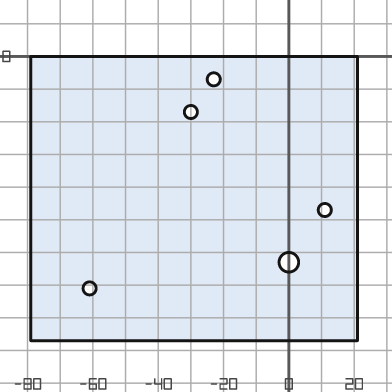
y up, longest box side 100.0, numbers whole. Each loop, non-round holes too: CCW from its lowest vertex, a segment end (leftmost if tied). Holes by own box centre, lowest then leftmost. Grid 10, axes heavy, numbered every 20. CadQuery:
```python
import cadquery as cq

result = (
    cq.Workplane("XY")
    .moveTo(-79.0, -87.0)
    .lineTo(21.0, -87.0)
    .lineTo(21.0, 0.0)
    .lineTo(-79.0, 0.0)
    .close()
    .moveTo(-61.0, -71.0)
    .circle(2.0)
    .moveTo(0.0, -63.0)
    .circle(3.0)
    .moveTo(11.0, -47.0)
    .circle(2.0)
    .moveTo(-30.0, -17.0)
    .circle(2.0)
    .moveTo(-23.0, -7.0)
    .circle(2.0)
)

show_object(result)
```